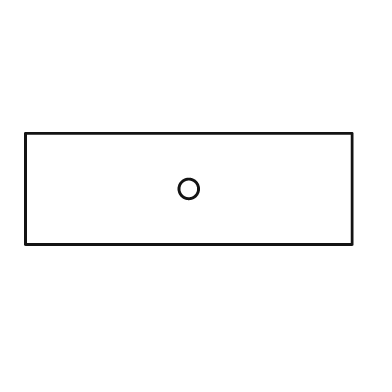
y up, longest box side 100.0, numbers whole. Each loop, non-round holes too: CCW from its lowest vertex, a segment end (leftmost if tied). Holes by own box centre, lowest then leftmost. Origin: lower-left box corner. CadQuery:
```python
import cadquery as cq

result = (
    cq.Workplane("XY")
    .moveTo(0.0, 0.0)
    .lineTo(100.0, 0.0)
    .lineTo(100.0, 34.0)
    .lineTo(0.0, 34.0)
    .close()
    .moveTo(50.0, 17.0)
    .circle(3.0)
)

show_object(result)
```